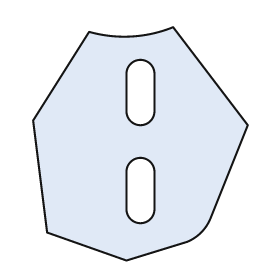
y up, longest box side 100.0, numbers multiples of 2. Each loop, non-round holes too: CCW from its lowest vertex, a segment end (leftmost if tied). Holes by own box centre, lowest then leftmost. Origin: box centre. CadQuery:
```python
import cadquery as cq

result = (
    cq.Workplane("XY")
    .moveTo(-6.0, -50.0)
    .lineTo(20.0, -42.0)
    .threePointArc((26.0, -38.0), (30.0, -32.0))
    .lineTo(46.0, 8.0)
    .lineTo(14.0, 50.0)
    .threePointArc((-4.0, 46.0), (-22.0, 48.0))
    .lineTo(-46.0, 10.0)
    .lineTo(-40.0, -38.0)
    .close()
    .moveTo(-6.0, -28.0)
    .threePointArc((0.0, -34.0), (6.0, -28.0))
    .lineTo(6.0, -12.0)
    .threePointArc((0.0, -6.0), (-6.0, -12.0))
    .close()
    .moveTo(-6.0, 14.0)
    .threePointArc((0.0, 8.0), (6.0, 14.0))
    .lineTo(6.0, 30.0)
    .threePointArc((0.0, 36.0), (-6.0, 30.0))
    .close()
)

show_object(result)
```